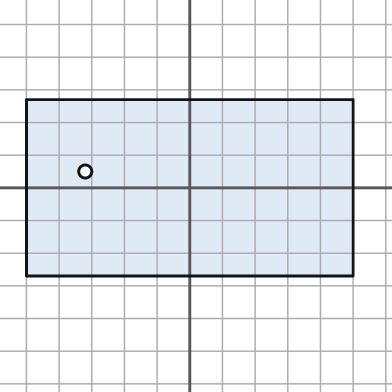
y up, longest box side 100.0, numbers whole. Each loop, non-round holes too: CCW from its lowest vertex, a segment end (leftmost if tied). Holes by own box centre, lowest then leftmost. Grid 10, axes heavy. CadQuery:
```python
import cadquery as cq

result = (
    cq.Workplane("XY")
    .moveTo(-50.0, -27.0)
    .lineTo(50.0, -27.0)
    .lineTo(50.0, 27.0)
    .lineTo(-50.0, 27.0)
    .close()
    .moveTo(-32.0, 5.0)
    .circle(2.0)
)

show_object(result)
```